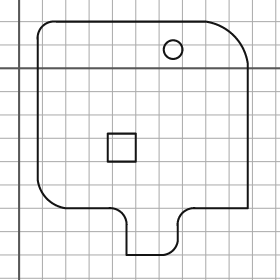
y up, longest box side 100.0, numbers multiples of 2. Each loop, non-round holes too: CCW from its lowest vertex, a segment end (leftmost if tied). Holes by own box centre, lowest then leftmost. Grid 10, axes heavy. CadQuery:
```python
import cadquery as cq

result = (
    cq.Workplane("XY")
    .moveTo(46.0, -80.0)
    .lineTo(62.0, -80.0)
    .threePointArc((66.0, -78.0), (68.0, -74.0))
    .lineTo(68.0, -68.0)
    .threePointArc((70.0, -62.0), (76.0, -60.0))
    .lineTo(98.0, -60.0)
    .lineTo(98.0, 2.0)
    .threePointArc((92.0, 14.0), (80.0, 20.0))
    .lineTo(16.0, 20.0)
    .threePointArc((10.0, 18.0), (8.0, 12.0))
    .lineTo(8.0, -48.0)
    .threePointArc((12.0, -56.0), (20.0, -60.0))
    .lineTo(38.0, -60.0)
    .threePointArc((44.0, -62.0), (46.0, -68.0))
    .close()
    .moveTo(38.0, -40.0)
    .lineTo(50.0, -40.0)
    .lineTo(50.0, -28.0)
    .lineTo(38.0, -28.0)
    .close()
    .moveTo(66.0, 8.0)
    .circle(4.0)
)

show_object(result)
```